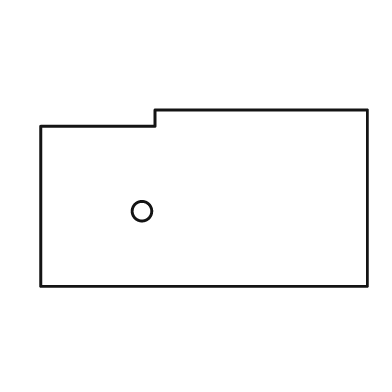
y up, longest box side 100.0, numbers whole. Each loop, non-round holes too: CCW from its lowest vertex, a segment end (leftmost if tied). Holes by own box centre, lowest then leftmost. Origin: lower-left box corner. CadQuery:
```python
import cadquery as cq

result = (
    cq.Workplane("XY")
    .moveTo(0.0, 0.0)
    .lineTo(100.0, 0.0)
    .lineTo(100.0, 54.0)
    .lineTo(35.0, 54.0)
    .lineTo(35.0, 49.0)
    .lineTo(0.0, 49.0)
    .close()
    .moveTo(31.0, 23.0)
    .circle(3.0)
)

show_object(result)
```